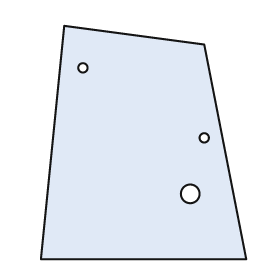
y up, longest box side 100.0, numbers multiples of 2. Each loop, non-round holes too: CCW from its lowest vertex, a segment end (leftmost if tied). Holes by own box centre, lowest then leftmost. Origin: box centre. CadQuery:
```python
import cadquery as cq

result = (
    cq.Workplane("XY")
    .moveTo(-44.0, -50.0)
    .lineTo(44.0, -50.0)
    .lineTo(26.0, 42.0)
    .lineTo(-34.0, 50.0)
    .close()
    .moveTo(20.0, -22.0)
    .circle(4.0)
    .moveTo(26.0, 2.0)
    .circle(2.0)
    .moveTo(-26.0, 32.0)
    .circle(2.0)
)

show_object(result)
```